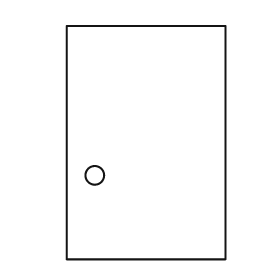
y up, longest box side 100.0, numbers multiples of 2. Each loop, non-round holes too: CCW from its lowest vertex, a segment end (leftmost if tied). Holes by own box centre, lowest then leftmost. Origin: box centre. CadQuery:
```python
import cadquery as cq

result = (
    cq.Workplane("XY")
    .moveTo(-34.0, -50.0)
    .lineTo(34.0, -50.0)
    .lineTo(34.0, 50.0)
    .lineTo(-34.0, 50.0)
    .close()
    .moveTo(-22.0, -14.0)
    .circle(4.0)
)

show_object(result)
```